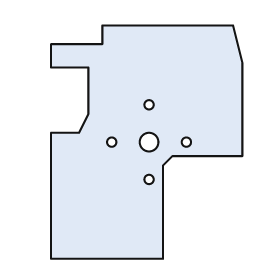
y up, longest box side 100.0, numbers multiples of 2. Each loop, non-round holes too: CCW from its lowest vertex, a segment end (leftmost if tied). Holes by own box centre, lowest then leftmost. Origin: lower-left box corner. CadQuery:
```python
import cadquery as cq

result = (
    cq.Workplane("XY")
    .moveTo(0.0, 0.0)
    .lineTo(48.0, 0.0)
    .lineTo(48.0, 40.0)
    .lineTo(52.0, 44.0)
    .lineTo(82.0, 44.0)
    .lineTo(82.0, 84.0)
    .lineTo(78.0, 100.0)
    .lineTo(22.0, 100.0)
    .lineTo(22.0, 92.0)
    .lineTo(0.0, 92.0)
    .lineTo(0.0, 82.0)
    .lineTo(16.0, 82.0)
    .lineTo(16.0, 62.0)
    .lineTo(12.0, 54.0)
    .lineTo(0.0, 54.0)
    .close()
    .moveTo(42.0, 34.0)
    .circle(2.0)
    .moveTo(26.0, 50.0)
    .circle(2.0)
    .moveTo(42.0, 50.0)
    .circle(4.0)
    .moveTo(58.0, 50.0)
    .circle(2.0)
    .moveTo(42.0, 66.0)
    .circle(2.0)
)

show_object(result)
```